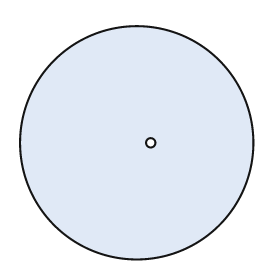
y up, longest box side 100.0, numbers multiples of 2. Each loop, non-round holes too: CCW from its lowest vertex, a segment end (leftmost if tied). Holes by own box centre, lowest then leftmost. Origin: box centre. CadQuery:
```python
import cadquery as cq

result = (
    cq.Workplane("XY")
    .moveTo(0.0, 0.0)
    .circle(50.0)
    .moveTo(6.0, 0.0)
    .circle(2.0)
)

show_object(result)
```